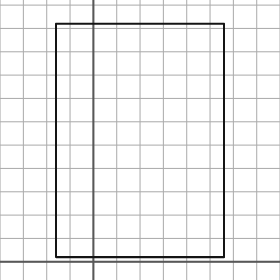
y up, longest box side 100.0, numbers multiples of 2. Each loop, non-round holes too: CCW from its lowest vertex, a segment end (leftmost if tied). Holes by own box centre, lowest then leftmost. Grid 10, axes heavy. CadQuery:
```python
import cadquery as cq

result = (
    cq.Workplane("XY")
    .moveTo(-16.0, 2.0)
    .lineTo(56.0, 2.0)
    .lineTo(56.0, 102.0)
    .lineTo(-16.0, 102.0)
    .close()
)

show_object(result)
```